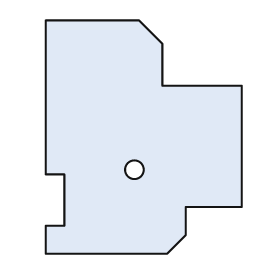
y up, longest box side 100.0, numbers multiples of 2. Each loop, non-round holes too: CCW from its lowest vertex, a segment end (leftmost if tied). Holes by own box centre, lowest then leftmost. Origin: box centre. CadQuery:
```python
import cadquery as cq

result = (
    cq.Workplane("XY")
    .moveTo(-42.0, -50.0)
    .lineTo(10.0, -50.0)
    .lineTo(18.0, -42.0)
    .lineTo(18.0, -30.0)
    .lineTo(42.0, -30.0)
    .lineTo(42.0, 22.0)
    .lineTo(8.0, 22.0)
    .lineTo(8.0, 40.0)
    .lineTo(-2.0, 50.0)
    .lineTo(-42.0, 50.0)
    .lineTo(-42.0, -16.0)
    .lineTo(-34.0, -16.0)
    .lineTo(-34.0, -38.0)
    .lineTo(-42.0, -38.0)
    .close()
    .moveTo(-4.0, -14.0)
    .circle(4.0)
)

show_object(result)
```